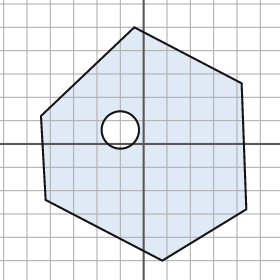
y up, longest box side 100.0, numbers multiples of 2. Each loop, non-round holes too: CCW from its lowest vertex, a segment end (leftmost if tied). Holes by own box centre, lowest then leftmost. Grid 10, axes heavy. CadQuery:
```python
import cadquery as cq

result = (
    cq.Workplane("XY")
    .moveTo(8.0, -50.0)
    .lineTo(44.0, -28.0)
    .lineTo(42.0, 26.0)
    .lineTo(-4.0, 50.0)
    .lineTo(-44.0, 12.0)
    .lineTo(-42.0, -24.0)
    .close()
    .moveTo(-10.0, 6.0)
    .circle(8.0)
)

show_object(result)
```